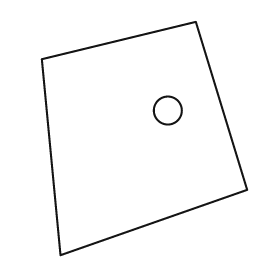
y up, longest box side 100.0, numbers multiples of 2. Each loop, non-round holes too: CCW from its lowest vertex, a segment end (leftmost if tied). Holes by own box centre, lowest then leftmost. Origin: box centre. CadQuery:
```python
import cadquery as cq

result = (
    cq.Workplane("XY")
    .moveTo(-36.0, -50.0)
    .lineTo(44.0, -22.0)
    .lineTo(22.0, 50.0)
    .lineTo(-44.0, 34.0)
    .close()
    .moveTo(10.0, 12.0)
    .circle(6.0)
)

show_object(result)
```